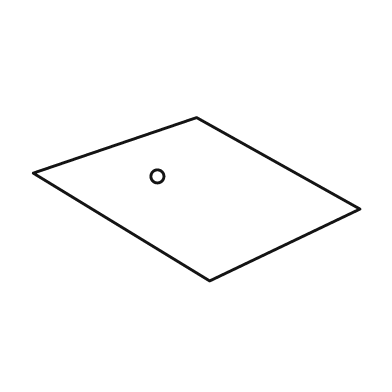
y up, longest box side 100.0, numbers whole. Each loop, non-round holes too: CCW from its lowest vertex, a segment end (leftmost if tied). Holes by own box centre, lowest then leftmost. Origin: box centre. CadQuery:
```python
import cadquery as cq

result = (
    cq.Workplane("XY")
    .moveTo(4.0, -25.0)
    .lineTo(50.0, -3.0)
    .lineTo(0.0, 25.0)
    .lineTo(-50.0, 8.0)
    .close()
    .moveTo(-12.0, 7.0)
    .circle(2.0)
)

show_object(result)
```